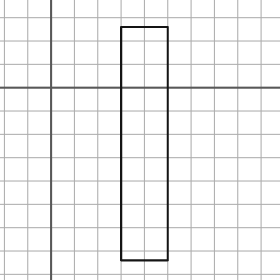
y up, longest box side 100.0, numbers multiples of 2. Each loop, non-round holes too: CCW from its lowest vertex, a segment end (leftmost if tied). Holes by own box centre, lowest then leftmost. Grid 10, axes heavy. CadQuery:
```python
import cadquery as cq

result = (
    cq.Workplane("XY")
    .moveTo(30.0, -74.0)
    .lineTo(50.0, -74.0)
    .lineTo(50.0, 26.0)
    .lineTo(30.0, 26.0)
    .close()
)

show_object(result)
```